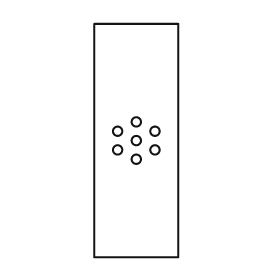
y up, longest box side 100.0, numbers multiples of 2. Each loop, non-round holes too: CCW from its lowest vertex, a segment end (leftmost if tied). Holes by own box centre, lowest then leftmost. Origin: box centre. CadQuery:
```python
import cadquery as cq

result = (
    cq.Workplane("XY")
    .moveTo(-18.0, -50.0)
    .lineTo(18.0, -50.0)
    .lineTo(18.0, 50.0)
    .lineTo(-18.0, 50.0)
    .close()
    .moveTo(0.0, -8.0)
    .circle(2.0)
    .moveTo(-8.0, -4.0)
    .circle(2.0)
    .moveTo(8.0, -4.0)
    .circle(2.0)
    .moveTo(0.0, 0.0)
    .circle(2.0)
    .moveTo(-8.0, 4.0)
    .circle(2.0)
    .moveTo(8.0, 4.0)
    .circle(2.0)
    .moveTo(0.0, 8.0)
    .circle(2.0)
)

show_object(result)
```